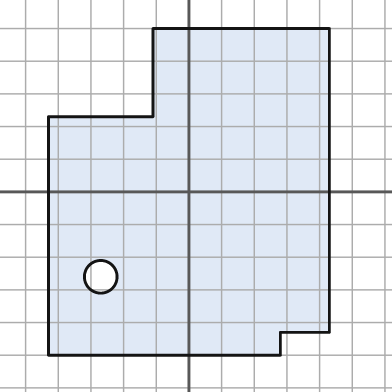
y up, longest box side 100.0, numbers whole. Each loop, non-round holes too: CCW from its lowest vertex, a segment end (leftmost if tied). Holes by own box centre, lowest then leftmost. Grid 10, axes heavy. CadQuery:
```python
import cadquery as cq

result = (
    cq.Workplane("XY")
    .moveTo(-43.0, -50.0)
    .lineTo(28.0, -50.0)
    .lineTo(28.0, -43.0)
    .lineTo(43.0, -43.0)
    .lineTo(43.0, 50.0)
    .lineTo(-11.0, 50.0)
    .lineTo(-11.0, 23.0)
    .lineTo(-43.0, 23.0)
    .close()
    .moveTo(-27.0, -26.0)
    .circle(5.0)
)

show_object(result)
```